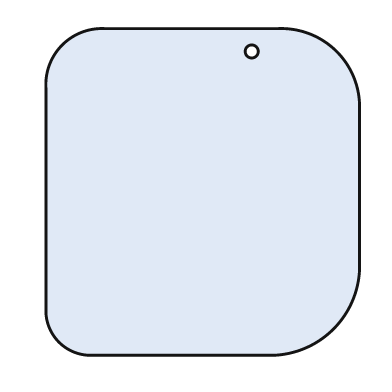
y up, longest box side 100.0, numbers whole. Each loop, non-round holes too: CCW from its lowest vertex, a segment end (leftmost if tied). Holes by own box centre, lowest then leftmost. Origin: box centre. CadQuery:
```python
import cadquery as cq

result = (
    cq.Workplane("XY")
    .moveTo(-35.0, -50.0)
    .lineTo(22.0, -50.0)
    .threePointArc((40.0, -42.0), (48.0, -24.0))
    .lineTo(48.0, 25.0)
    .threePointArc((41.0, 43.0), (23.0, 50.0))
    .lineTo(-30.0, 50.0)
    .threePointArc((-43.0, 45.0), (-48.0, 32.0))
    .lineTo(-48.0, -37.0)
    .threePointArc((-44.0, -46.0), (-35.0, -50.0))
    .close()
    .moveTo(15.0, 43.0)
    .circle(2.0)
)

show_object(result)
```